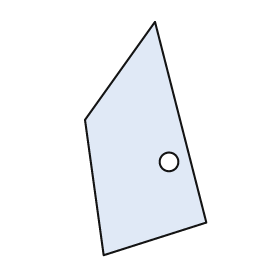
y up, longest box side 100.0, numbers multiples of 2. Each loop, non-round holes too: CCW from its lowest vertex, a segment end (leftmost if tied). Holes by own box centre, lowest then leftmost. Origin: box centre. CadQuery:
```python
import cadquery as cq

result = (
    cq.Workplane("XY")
    .moveTo(-18.0, -50.0)
    .lineTo(26.0, -36.0)
    .lineTo(4.0, 50.0)
    .lineTo(-26.0, 8.0)
    .close()
    .moveTo(10.0, -10.0)
    .circle(4.0)
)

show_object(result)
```